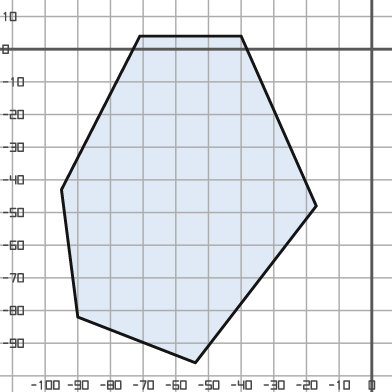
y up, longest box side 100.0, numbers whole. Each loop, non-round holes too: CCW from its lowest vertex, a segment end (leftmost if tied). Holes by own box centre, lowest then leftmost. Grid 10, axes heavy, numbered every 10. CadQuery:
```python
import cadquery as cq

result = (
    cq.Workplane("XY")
    .moveTo(-54.0, -96.0)
    .lineTo(-17.0, -48.0)
    .lineTo(-40.0, 4.0)
    .lineTo(-71.0, 4.0)
    .lineTo(-95.0, -43.0)
    .lineTo(-90.0, -82.0)
    .close()
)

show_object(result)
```